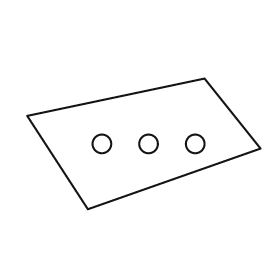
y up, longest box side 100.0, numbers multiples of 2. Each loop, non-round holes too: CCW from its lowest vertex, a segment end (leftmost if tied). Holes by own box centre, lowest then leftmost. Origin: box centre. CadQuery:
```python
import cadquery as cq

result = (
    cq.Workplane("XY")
    .moveTo(-24.0, -28.0)
    .lineTo(50.0, -2.0)
    .lineTo(26.0, 28.0)
    .lineTo(-50.0, 12.0)
    .close()
    .moveTo(-18.0, 0.0)
    .circle(4.0)
    .moveTo(2.0, 0.0)
    .circle(4.0)
    .moveTo(22.0, 0.0)
    .circle(4.0)
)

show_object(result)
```